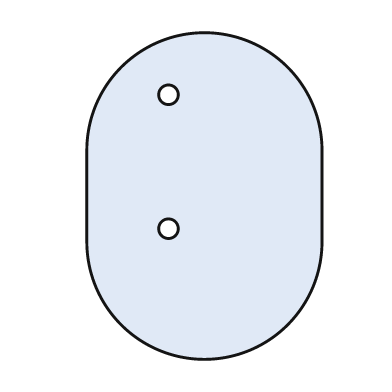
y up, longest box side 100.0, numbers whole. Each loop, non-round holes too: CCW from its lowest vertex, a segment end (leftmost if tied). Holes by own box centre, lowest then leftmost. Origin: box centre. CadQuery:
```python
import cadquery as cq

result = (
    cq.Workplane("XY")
    .moveTo(-36.0, -14.0)
    .threePointArc((0.0, -50.0), (36.0, -14.0))
    .lineTo(36.0, 14.0)
    .threePointArc((0.0, 50.0), (-36.0, 14.0))
    .close()
    .moveTo(-11.0, -10.0)
    .circle(3.0)
    .moveTo(-11.0, 31.0)
    .circle(3.0)
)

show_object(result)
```